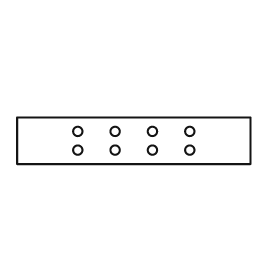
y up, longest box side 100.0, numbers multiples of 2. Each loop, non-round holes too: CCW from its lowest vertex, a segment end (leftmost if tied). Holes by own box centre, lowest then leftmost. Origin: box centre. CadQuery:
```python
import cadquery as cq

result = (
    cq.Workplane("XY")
    .moveTo(-50.0, -10.0)
    .lineTo(50.0, -10.0)
    .lineTo(50.0, 10.0)
    .lineTo(-50.0, 10.0)
    .close()
    .moveTo(-24.0, -4.0)
    .circle(2.0)
    .moveTo(-8.0, -4.0)
    .circle(2.0)
    .moveTo(8.0, -4.0)
    .circle(2.0)
    .moveTo(24.0, -4.0)
    .circle(2.0)
    .moveTo(-24.0, 4.0)
    .circle(2.0)
    .moveTo(-8.0, 4.0)
    .circle(2.0)
    .moveTo(8.0, 4.0)
    .circle(2.0)
    .moveTo(24.0, 4.0)
    .circle(2.0)
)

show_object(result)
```